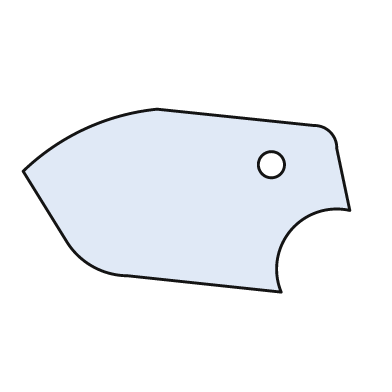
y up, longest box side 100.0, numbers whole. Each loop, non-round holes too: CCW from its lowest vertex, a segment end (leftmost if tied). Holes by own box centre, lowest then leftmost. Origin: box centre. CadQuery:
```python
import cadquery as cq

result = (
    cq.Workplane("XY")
    .moveTo(29.0, -28.0)
    .threePointArc((32.0, -9.0), (50.0, -3.0))
    .lineTo(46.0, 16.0)
    .threePointArc((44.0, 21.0), (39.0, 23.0))
    .lineTo(-9.0, 28.0)
    .threePointArc((-31.0, 22.0), (-50.0, 9.0))
    .lineTo(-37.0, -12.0)
    .threePointArc((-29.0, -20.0), (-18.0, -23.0))
    .close()
    .moveTo(26.0, 11.0)
    .circle(4.0)
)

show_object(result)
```